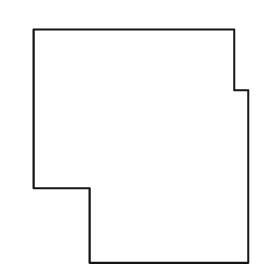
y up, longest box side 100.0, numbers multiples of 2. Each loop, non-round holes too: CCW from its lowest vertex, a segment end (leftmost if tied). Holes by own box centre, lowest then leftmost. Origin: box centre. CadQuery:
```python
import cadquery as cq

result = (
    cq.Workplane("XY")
    .moveTo(-22.0, -50.0)
    .lineTo(46.0, -50.0)
    .lineTo(46.0, 24.0)
    .lineTo(40.0, 24.0)
    .lineTo(40.0, 50.0)
    .lineTo(-46.0, 50.0)
    .lineTo(-46.0, -18.0)
    .lineTo(-22.0, -18.0)
    .close()
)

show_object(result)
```